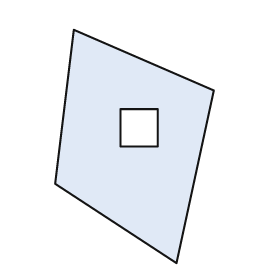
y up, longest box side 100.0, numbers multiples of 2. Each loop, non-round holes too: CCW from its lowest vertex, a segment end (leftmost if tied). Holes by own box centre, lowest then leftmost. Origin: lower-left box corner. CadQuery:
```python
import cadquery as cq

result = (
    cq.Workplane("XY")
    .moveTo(52.0, 0.0)
    .lineTo(68.0, 74.0)
    .lineTo(8.0, 100.0)
    .lineTo(0.0, 34.0)
    .close()
    .moveTo(28.0, 50.0)
    .lineTo(44.0, 50.0)
    .lineTo(44.0, 66.0)
    .lineTo(28.0, 66.0)
    .close()
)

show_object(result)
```